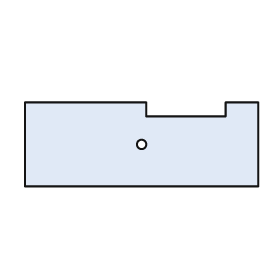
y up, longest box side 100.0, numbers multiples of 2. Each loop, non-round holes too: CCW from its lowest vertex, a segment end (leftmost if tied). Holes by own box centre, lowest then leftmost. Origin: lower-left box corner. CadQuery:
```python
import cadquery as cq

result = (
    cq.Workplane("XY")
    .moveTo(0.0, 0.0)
    .lineTo(100.0, 0.0)
    .lineTo(100.0, 36.0)
    .lineTo(86.0, 36.0)
    .lineTo(86.0, 30.0)
    .lineTo(52.0, 30.0)
    .lineTo(52.0, 36.0)
    .lineTo(0.0, 36.0)
    .close()
    .moveTo(50.0, 18.0)
    .circle(2.0)
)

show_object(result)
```